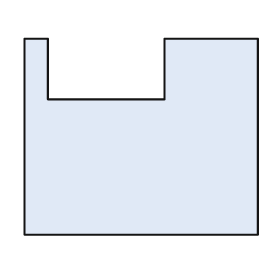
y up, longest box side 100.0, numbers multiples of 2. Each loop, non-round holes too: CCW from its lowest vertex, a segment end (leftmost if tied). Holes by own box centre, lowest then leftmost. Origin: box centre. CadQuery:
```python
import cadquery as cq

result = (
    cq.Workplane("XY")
    .moveTo(-50.0, -42.0)
    .lineTo(50.0, -42.0)
    .lineTo(50.0, 42.0)
    .lineTo(10.0, 42.0)
    .lineTo(10.0, 16.0)
    .lineTo(-40.0, 16.0)
    .lineTo(-40.0, 42.0)
    .lineTo(-50.0, 42.0)
    .close()
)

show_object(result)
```